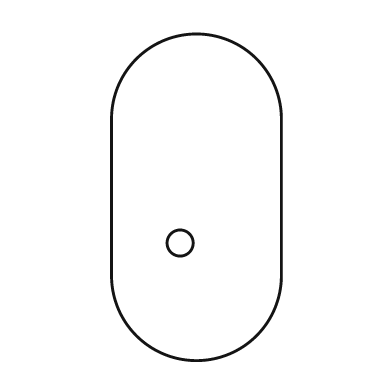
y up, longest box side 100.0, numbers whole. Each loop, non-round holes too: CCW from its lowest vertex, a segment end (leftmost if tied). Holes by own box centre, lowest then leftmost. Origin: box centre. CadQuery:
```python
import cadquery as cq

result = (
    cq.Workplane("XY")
    .moveTo(-26.0, -24.0)
    .threePointArc((0.0, -50.0), (26.0, -24.0))
    .lineTo(26.0, 24.0)
    .threePointArc((0.0, 50.0), (-26.0, 24.0))
    .close()
    .moveTo(-5.0, -14.0)
    .circle(4.0)
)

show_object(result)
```